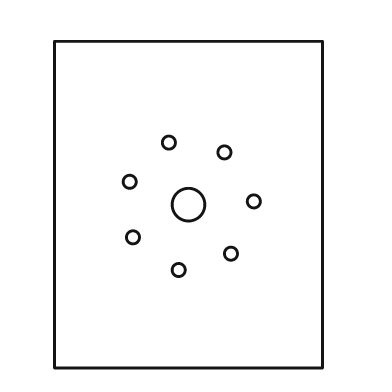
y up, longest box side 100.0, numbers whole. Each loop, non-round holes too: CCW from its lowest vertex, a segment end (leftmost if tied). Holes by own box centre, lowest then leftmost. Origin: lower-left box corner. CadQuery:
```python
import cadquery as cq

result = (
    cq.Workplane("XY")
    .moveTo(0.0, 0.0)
    .lineTo(82.0, 0.0)
    .lineTo(82.0, 100.0)
    .lineTo(0.0, 100.0)
    .close()
    .moveTo(38.0, 30.0)
    .circle(2.0)
    .moveTo(54.0, 35.0)
    .circle(2.0)
    .moveTo(24.0, 40.0)
    .circle(2.0)
    .moveTo(41.0, 50.0)
    .circle(5.0)
    .moveTo(61.0, 51.0)
    .circle(2.0)
    .moveTo(23.0, 57.0)
    .circle(2.0)
    .moveTo(52.0, 66.0)
    .circle(2.0)
    .moveTo(35.0, 69.0)
    .circle(2.0)
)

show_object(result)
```